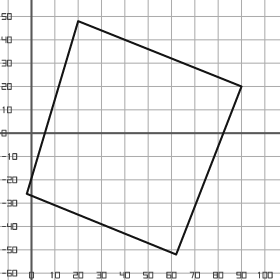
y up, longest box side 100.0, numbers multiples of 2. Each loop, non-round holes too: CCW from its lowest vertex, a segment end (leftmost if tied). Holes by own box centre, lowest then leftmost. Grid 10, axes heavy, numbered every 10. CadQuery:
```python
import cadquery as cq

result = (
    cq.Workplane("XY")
    .moveTo(62.0, -52.0)
    .lineTo(90.0, 20.0)
    .lineTo(20.0, 48.0)
    .lineTo(-2.0, -26.0)
    .close()
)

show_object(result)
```